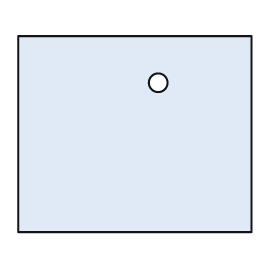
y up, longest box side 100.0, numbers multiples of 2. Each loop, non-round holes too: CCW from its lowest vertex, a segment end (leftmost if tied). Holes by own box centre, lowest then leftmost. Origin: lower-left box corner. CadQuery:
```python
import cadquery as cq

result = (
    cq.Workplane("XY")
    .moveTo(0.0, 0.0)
    .lineTo(100.0, 0.0)
    .lineTo(100.0, 84.0)
    .lineTo(0.0, 84.0)
    .close()
    .moveTo(60.0, 64.0)
    .circle(4.0)
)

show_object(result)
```